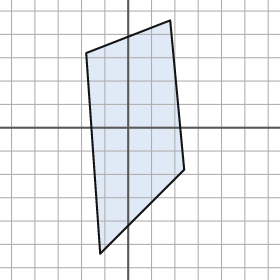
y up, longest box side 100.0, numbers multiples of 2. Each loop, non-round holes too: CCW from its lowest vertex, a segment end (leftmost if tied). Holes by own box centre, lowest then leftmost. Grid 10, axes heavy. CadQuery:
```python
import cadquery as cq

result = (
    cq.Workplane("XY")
    .moveTo(-12.0, -54.0)
    .lineTo(24.0, -18.0)
    .lineTo(18.0, 46.0)
    .lineTo(-18.0, 32.0)
    .close()
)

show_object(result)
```